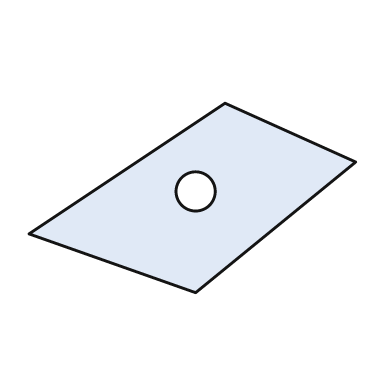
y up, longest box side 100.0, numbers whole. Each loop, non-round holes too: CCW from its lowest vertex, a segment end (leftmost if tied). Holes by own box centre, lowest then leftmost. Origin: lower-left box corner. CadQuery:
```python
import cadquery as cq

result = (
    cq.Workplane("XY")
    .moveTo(51.0, 0.0)
    .lineTo(100.0, 40.0)
    .lineTo(60.0, 58.0)
    .lineTo(0.0, 18.0)
    .close()
    .moveTo(51.0, 31.0)
    .circle(6.0)
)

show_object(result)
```